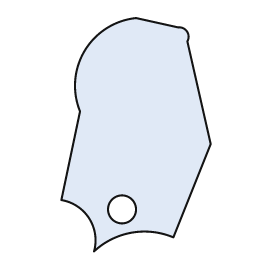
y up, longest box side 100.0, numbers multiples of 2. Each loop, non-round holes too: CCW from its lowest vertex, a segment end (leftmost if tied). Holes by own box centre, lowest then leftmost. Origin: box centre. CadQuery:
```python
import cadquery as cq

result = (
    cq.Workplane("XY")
    .moveTo(-18.0, -50.0)
    .threePointArc((-2.0, -42.0), (16.0, -44.0))
    .lineTo(32.0, -4.0)
    .lineTo(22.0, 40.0)
    .threePointArc((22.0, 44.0), (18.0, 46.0))
    .lineTo(0.0, 50.0)
    .threePointArc((-22.0, 36.0), (-24.0, 10.0))
    .lineTo(-32.0, -28.0)
    .threePointArc((-20.0, -36.0), (-18.0, -50.0))
    .close()
    .moveTo(-6.0, -32.0)
    .circle(6.0)
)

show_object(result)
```